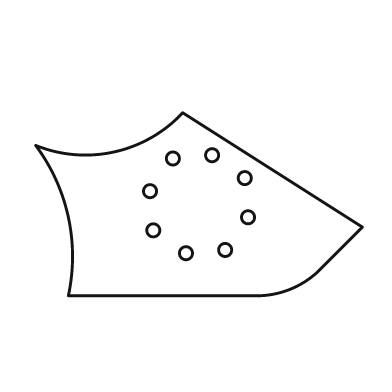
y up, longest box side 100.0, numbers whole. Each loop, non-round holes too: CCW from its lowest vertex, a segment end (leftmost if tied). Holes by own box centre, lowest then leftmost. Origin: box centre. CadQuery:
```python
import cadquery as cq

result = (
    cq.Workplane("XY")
    .moveTo(-40.0, -28.0)
    .lineTo(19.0, -28.0)
    .threePointArc((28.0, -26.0), (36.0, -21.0))
    .lineTo(50.0, -7.0)
    .lineTo(-5.0, 28.0)
    .threePointArc((-26.0, 16.0), (-50.0, 18.0))
    .threePointArc((-40.0, -4.0), (-40.0, -28.0))
    .close()
    .moveTo(-4.0, -15.0)
    .circle(2.0)
    .moveTo(8.0, -14.0)
    .circle(2.0)
    .moveTo(-14.0, -8.0)
    .circle(2.0)
    .moveTo(15.0, -4.0)
    .circle(2.0)
    .moveTo(-15.0, 4.0)
    .circle(2.0)
    .moveTo(14.0, 8.0)
    .circle(2.0)
    .moveTo(-8.0, 14.0)
    .circle(2.0)
    .moveTo(4.0, 15.0)
    .circle(2.0)
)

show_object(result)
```